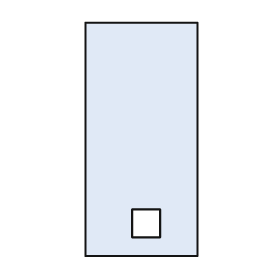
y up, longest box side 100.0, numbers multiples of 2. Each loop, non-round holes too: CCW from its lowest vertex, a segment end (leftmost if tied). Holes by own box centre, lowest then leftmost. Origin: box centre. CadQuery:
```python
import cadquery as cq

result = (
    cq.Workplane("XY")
    .moveTo(-24.0, -50.0)
    .lineTo(24.0, -50.0)
    .lineTo(24.0, 50.0)
    .lineTo(-24.0, 50.0)
    .close()
    .moveTo(-4.0, -42.0)
    .lineTo(8.0, -42.0)
    .lineTo(8.0, -30.0)
    .lineTo(-4.0, -30.0)
    .close()
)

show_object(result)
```